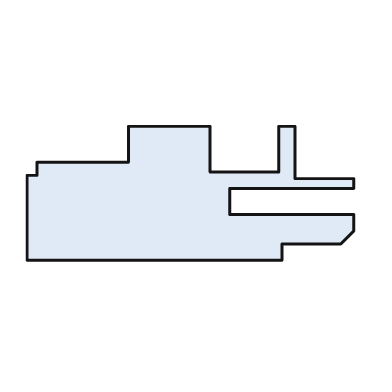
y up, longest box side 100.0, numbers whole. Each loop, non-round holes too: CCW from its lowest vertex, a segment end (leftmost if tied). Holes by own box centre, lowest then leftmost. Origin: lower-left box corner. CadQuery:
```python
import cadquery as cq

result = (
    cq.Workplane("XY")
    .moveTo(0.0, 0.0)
    .lineTo(78.0, 0.0)
    .lineTo(78.0, 5.0)
    .lineTo(96.0, 5.0)
    .lineTo(100.0, 9.0)
    .lineTo(100.0, 14.0)
    .lineTo(62.0, 14.0)
    .lineTo(62.0, 22.0)
    .lineTo(100.0, 22.0)
    .lineTo(100.0, 25.0)
    .lineTo(82.0, 25.0)
    .lineTo(82.0, 41.0)
    .lineTo(77.0, 41.0)
    .lineTo(77.0, 27.0)
    .lineTo(56.0, 27.0)
    .lineTo(56.0, 41.0)
    .lineTo(31.0, 41.0)
    .lineTo(31.0, 30.0)
    .lineTo(3.0, 30.0)
    .lineTo(3.0, 26.0)
    .lineTo(0.0, 26.0)
    .close()
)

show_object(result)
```